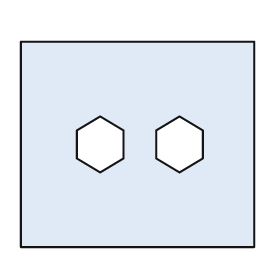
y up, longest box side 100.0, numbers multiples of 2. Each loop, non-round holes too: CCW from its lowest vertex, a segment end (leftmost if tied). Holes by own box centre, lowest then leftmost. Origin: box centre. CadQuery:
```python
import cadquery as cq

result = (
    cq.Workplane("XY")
    .moveTo(-50.0, -44.0)
    .lineTo(50.0, -44.0)
    .lineTo(50.0, 44.0)
    .lineTo(-50.0, 44.0)
    .close()
    .moveTo(-16.0, -12.0)
    .lineTo(-6.0, -6.0)
    .lineTo(-6.0, 6.0)
    .lineTo(-16.0, 12.0)
    .lineTo(-26.0, 6.0)
    .lineTo(-26.0, -6.0)
    .close()
    .moveTo(18.0, -12.0)
    .lineTo(28.0, -6.0)
    .lineTo(28.0, 6.0)
    .lineTo(18.0, 12.0)
    .lineTo(8.0, 6.0)
    .lineTo(8.0, -6.0)
    .close()
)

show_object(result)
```